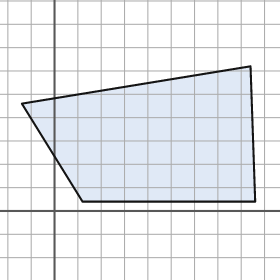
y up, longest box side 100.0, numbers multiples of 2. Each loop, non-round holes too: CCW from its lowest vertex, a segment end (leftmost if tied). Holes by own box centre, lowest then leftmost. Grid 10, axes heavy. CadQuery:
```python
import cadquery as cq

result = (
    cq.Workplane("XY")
    .moveTo(12.0, 4.0)
    .lineTo(86.0, 4.0)
    .lineTo(84.0, 62.0)
    .lineTo(-14.0, 46.0)
    .close()
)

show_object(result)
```